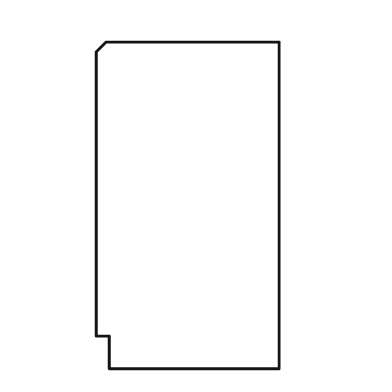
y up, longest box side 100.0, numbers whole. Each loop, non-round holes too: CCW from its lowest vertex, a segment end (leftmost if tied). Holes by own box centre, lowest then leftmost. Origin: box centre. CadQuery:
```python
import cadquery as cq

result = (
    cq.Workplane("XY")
    .moveTo(-24.0, -50.0)
    .lineTo(28.0, -50.0)
    .lineTo(28.0, 50.0)
    .lineTo(-25.0, 50.0)
    .lineTo(-28.0, 47.0)
    .lineTo(-28.0, -40.0)
    .lineTo(-24.0, -40.0)
    .close()
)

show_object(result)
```